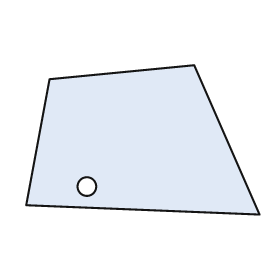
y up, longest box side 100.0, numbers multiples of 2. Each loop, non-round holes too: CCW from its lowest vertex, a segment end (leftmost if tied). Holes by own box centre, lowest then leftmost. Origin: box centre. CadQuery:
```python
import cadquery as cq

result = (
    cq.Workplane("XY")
    .moveTo(50.0, -32.0)
    .lineTo(22.0, 32.0)
    .lineTo(-40.0, 26.0)
    .lineTo(-50.0, -28.0)
    .close()
    .moveTo(-24.0, -20.0)
    .circle(4.0)
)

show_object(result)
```